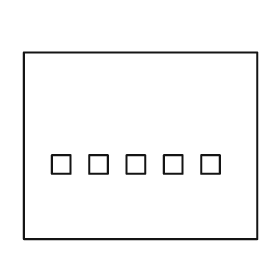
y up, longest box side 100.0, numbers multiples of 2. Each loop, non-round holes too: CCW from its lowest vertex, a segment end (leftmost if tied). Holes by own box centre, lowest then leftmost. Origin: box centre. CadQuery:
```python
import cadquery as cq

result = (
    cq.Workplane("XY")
    .moveTo(-50.0, -40.0)
    .lineTo(50.0, -40.0)
    .lineTo(50.0, 40.0)
    .lineTo(-50.0, 40.0)
    .close()
    .moveTo(-38.0, -12.0)
    .lineTo(-30.0, -12.0)
    .lineTo(-30.0, -4.0)
    .lineTo(-38.0, -4.0)
    .close()
    .moveTo(-22.0, -12.0)
    .lineTo(-14.0, -12.0)
    .lineTo(-14.0, -4.0)
    .lineTo(-22.0, -4.0)
    .close()
    .moveTo(-6.0, -12.0)
    .lineTo(2.0, -12.0)
    .lineTo(2.0, -4.0)
    .lineTo(-6.0, -4.0)
    .close()
    .moveTo(10.0, -12.0)
    .lineTo(18.0, -12.0)
    .lineTo(18.0, -4.0)
    .lineTo(10.0, -4.0)
    .close()
    .moveTo(26.0, -12.0)
    .lineTo(34.0, -12.0)
    .lineTo(34.0, -4.0)
    .lineTo(26.0, -4.0)
    .close()
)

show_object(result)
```